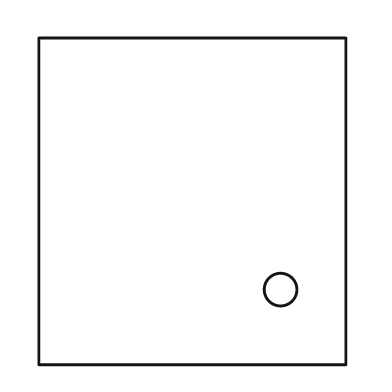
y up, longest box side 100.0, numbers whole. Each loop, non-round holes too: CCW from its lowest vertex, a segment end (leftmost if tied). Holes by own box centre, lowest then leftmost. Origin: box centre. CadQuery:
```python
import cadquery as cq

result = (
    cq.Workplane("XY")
    .moveTo(-47.0, -50.0)
    .lineTo(47.0, -50.0)
    .lineTo(47.0, 50.0)
    .lineTo(-47.0, 50.0)
    .close()
    .moveTo(27.0, -27.0)
    .circle(5.0)
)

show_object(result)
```